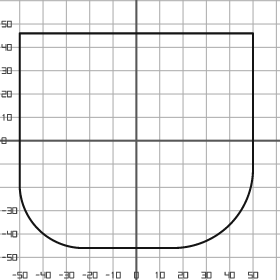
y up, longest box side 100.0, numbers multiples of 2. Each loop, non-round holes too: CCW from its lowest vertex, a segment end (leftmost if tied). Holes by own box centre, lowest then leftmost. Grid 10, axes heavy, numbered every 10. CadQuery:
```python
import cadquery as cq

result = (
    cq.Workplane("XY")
    .moveTo(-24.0, -46.0)
    .lineTo(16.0, -46.0)
    .threePointArc((40.0, -36.0), (50.0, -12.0))
    .lineTo(50.0, 46.0)
    .lineTo(-50.0, 46.0)
    .lineTo(-50.0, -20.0)
    .threePointArc((-42.0, -38.0), (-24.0, -46.0))
    .close()
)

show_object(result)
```